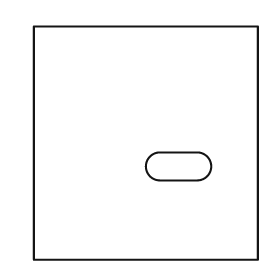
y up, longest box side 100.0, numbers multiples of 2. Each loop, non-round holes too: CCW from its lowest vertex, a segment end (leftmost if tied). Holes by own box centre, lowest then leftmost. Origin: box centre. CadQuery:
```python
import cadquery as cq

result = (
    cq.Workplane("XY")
    .moveTo(-48.0, -50.0)
    .lineTo(48.0, -50.0)
    .lineTo(48.0, 50.0)
    .lineTo(-48.0, 50.0)
    .close()
    .moveTo(6.0, -16.0)
    .lineTo(22.0, -16.0)
    .threePointArc((28.0, -10.0), (22.0, -4.0))
    .lineTo(6.0, -4.0)
    .threePointArc((0.0, -10.0), (6.0, -16.0))
    .close()
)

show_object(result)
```